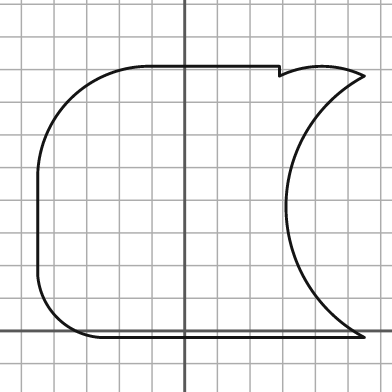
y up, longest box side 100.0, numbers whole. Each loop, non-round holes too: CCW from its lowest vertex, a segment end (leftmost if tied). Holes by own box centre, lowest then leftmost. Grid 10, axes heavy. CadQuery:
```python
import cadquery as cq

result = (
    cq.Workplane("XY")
    .moveTo(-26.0, -2.0)
    .lineTo(55.0, -2.0)
    .threePointArc((31.0, 38.0), (55.0, 78.0))
    .threePointArc((42.0, 81.0), (29.0, 78.0))
    .lineTo(29.0, 81.0)
    .lineTo(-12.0, 81.0)
    .threePointArc((-35.0, 71.0), (-45.0, 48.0))
    .lineTo(-45.0, 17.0)
    .threePointArc((-39.0, 4.0), (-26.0, -2.0))
    .close()
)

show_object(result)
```